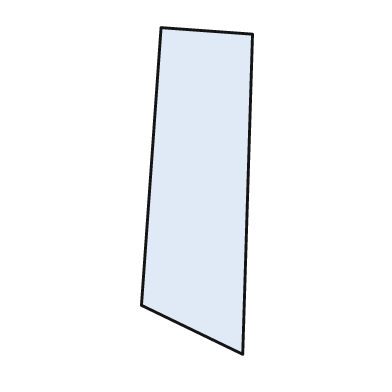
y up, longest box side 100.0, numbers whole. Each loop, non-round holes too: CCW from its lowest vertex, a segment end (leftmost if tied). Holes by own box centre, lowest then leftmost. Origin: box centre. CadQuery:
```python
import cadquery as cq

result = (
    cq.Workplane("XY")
    .moveTo(14.0, -50.0)
    .lineTo(17.0, 48.0)
    .lineTo(-11.0, 50.0)
    .lineTo(-17.0, -35.0)
    .close()
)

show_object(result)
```